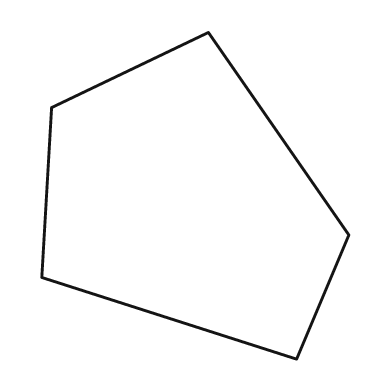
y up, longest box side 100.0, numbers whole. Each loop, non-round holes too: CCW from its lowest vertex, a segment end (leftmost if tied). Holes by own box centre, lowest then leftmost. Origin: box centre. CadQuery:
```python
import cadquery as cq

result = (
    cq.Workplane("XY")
    .moveTo(31.0, -50.0)
    .lineTo(47.0, -12.0)
    .lineTo(4.0, 50.0)
    .lineTo(-44.0, 27.0)
    .lineTo(-47.0, -25.0)
    .close()
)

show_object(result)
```